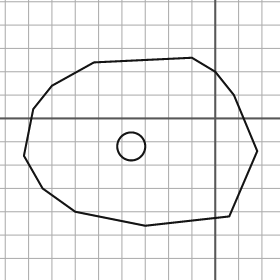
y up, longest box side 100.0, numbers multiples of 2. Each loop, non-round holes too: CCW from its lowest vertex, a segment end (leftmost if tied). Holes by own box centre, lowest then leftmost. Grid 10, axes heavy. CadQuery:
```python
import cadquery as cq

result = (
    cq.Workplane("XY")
    .moveTo(-30.0, -46.0)
    .lineTo(6.0, -42.0)
    .lineTo(18.0, -14.0)
    .lineTo(8.0, 10.0)
    .lineTo(0.0, 20.0)
    .lineTo(-10.0, 26.0)
    .lineTo(-52.0, 24.0)
    .lineTo(-70.0, 14.0)
    .lineTo(-78.0, 4.0)
    .lineTo(-82.0, -16.0)
    .lineTo(-74.0, -30.0)
    .lineTo(-60.0, -40.0)
    .close()
    .moveTo(-36.0, -12.0)
    .circle(6.0)
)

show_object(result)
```